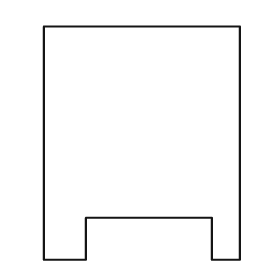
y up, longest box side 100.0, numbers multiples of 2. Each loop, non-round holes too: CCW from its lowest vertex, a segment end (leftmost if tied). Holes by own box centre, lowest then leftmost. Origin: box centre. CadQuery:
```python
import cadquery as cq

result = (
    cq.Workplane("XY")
    .moveTo(-42.0, -50.0)
    .lineTo(-24.0, -50.0)
    .lineTo(-24.0, -32.0)
    .lineTo(30.0, -32.0)
    .lineTo(30.0, -50.0)
    .lineTo(42.0, -50.0)
    .lineTo(42.0, 50.0)
    .lineTo(-42.0, 50.0)
    .close()
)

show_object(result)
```